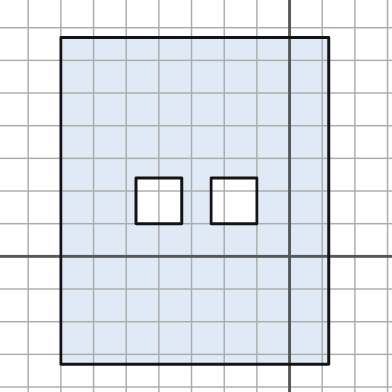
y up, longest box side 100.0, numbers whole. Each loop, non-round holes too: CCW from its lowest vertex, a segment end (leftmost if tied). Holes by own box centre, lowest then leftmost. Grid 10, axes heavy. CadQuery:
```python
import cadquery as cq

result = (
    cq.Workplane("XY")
    .moveTo(-70.0, -33.0)
    .lineTo(12.0, -33.0)
    .lineTo(12.0, 67.0)
    .lineTo(-70.0, 67.0)
    .close()
    .moveTo(-47.0, 10.0)
    .lineTo(-33.0, 10.0)
    .lineTo(-33.0, 24.0)
    .lineTo(-47.0, 24.0)
    .close()
    .moveTo(-24.0, 10.0)
    .lineTo(-10.0, 10.0)
    .lineTo(-10.0, 24.0)
    .lineTo(-24.0, 24.0)
    .close()
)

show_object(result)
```